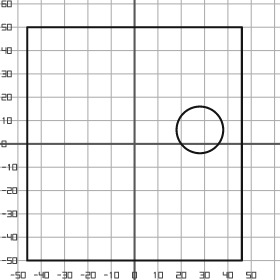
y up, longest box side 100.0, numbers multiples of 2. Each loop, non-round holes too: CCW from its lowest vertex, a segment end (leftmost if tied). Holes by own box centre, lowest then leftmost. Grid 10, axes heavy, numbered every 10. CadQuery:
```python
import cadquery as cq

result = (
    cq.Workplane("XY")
    .moveTo(-46.0, -50.0)
    .lineTo(46.0, -50.0)
    .lineTo(46.0, 50.0)
    .lineTo(-46.0, 50.0)
    .close()
    .moveTo(28.0, 6.0)
    .circle(10.0)
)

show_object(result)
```